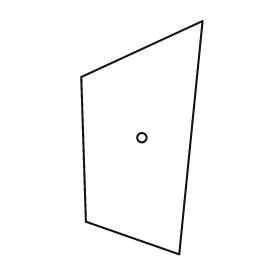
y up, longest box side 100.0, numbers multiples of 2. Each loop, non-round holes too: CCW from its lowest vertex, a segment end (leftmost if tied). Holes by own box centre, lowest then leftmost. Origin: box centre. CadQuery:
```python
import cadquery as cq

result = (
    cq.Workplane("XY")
    .moveTo(16.0, -50.0)
    .lineTo(26.0, 50.0)
    .lineTo(-26.0, 26.0)
    .lineTo(-24.0, -36.0)
    .close()
    .moveTo(0.0, 0.0)
    .circle(2.0)
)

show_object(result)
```